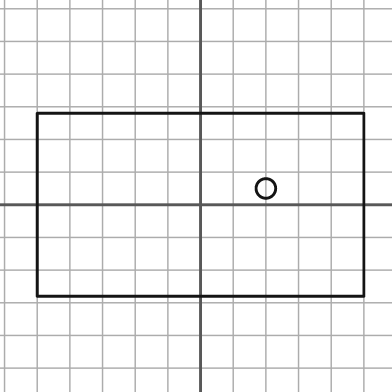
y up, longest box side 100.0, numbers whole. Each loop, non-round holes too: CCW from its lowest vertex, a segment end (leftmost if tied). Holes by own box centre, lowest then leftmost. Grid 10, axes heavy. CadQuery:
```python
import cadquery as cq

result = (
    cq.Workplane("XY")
    .moveTo(-50.0, -28.0)
    .lineTo(50.0, -28.0)
    .lineTo(50.0, 28.0)
    .lineTo(-50.0, 28.0)
    .close()
    .moveTo(20.0, 5.0)
    .circle(3.0)
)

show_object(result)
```